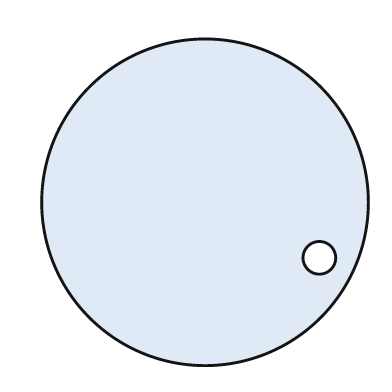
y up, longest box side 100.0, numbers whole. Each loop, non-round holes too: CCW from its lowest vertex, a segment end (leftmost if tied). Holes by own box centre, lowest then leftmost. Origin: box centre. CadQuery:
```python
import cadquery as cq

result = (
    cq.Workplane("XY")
    .moveTo(0.0, 0.0)
    .circle(50.0)
    .moveTo(35.0, -17.0)
    .circle(5.0)
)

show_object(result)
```